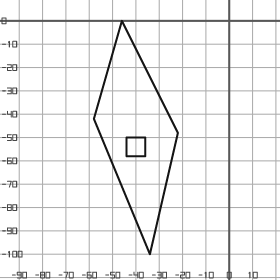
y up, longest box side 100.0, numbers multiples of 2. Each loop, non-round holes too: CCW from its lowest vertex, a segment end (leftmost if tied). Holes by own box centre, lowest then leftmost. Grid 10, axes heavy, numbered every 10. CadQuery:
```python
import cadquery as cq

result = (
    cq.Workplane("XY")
    .moveTo(-34.0, -100.0)
    .lineTo(-22.0, -48.0)
    .lineTo(-46.0, 0.0)
    .lineTo(-58.0, -42.0)
    .close()
    .moveTo(-44.0, -58.0)
    .lineTo(-36.0, -58.0)
    .lineTo(-36.0, -50.0)
    .lineTo(-44.0, -50.0)
    .close()
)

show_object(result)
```